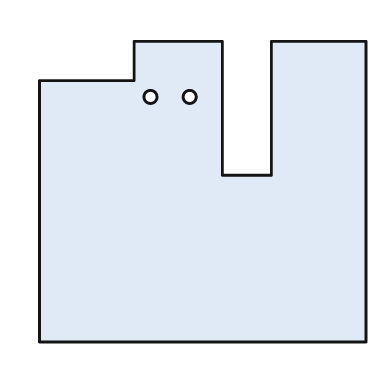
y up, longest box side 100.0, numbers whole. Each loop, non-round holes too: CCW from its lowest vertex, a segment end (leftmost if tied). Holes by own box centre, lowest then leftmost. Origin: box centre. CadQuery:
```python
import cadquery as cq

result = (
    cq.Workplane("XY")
    .moveTo(-50.0, -46.0)
    .lineTo(50.0, -46.0)
    .lineTo(50.0, 46.0)
    .lineTo(21.0, 46.0)
    .lineTo(21.0, 5.0)
    .lineTo(6.0, 5.0)
    .lineTo(6.0, 46.0)
    .lineTo(-21.0, 46.0)
    .lineTo(-21.0, 34.0)
    .lineTo(-50.0, 34.0)
    .close()
    .moveTo(-16.0, 29.0)
    .circle(2.0)
    .moveTo(-4.0, 29.0)
    .circle(2.0)
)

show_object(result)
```